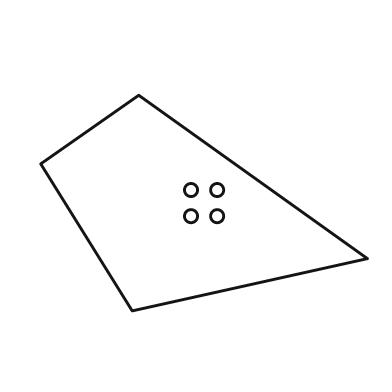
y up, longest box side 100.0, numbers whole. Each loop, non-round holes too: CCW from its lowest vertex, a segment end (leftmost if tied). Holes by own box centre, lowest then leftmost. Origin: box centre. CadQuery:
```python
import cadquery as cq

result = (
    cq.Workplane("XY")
    .moveTo(-22.0, -33.0)
    .lineTo(50.0, -17.0)
    .lineTo(-20.0, 33.0)
    .lineTo(-50.0, 12.0)
    .close()
    .moveTo(-4.0, -4.0)
    .circle(2.0)
    .moveTo(4.0, -4.0)
    .circle(2.0)
    .moveTo(-4.0, 4.0)
    .circle(2.0)
    .moveTo(4.0, 4.0)
    .circle(2.0)
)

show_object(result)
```